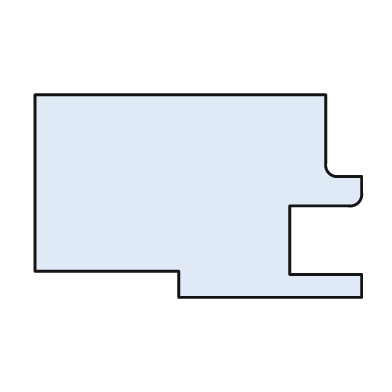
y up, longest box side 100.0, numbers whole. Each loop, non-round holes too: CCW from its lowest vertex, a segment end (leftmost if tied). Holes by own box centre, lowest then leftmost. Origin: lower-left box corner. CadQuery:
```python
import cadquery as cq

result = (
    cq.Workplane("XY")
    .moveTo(44.0, 0.0)
    .lineTo(100.0, 0.0)
    .lineTo(100.0, 7.0)
    .lineTo(78.0, 7.0)
    .lineTo(78.0, 28.0)
    .lineTo(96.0, 28.0)
    .threePointArc((99.0, 29.0), (100.0, 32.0))
    .lineTo(100.0, 37.0)
    .lineTo(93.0, 37.0)
    .threePointArc((90.0, 38.0), (89.0, 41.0))
    .lineTo(89.0, 62.0)
    .lineTo(0.0, 62.0)
    .lineTo(0.0, 8.0)
    .lineTo(44.0, 8.0)
    .close()
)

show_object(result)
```